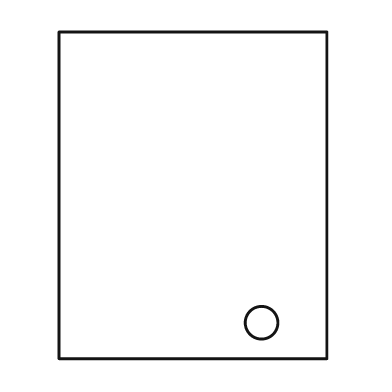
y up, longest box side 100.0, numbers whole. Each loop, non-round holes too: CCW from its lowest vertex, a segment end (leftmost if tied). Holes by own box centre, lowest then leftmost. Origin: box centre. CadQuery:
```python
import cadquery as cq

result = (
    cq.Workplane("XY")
    .moveTo(-41.0, -50.0)
    .lineTo(41.0, -50.0)
    .lineTo(41.0, 50.0)
    .lineTo(-41.0, 50.0)
    .close()
    .moveTo(21.0, -39.0)
    .circle(5.0)
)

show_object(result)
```